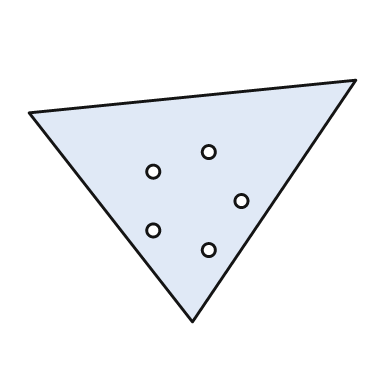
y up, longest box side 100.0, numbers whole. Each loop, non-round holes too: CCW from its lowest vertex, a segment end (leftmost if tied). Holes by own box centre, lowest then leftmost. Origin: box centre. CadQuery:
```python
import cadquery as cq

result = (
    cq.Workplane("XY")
    .moveTo(0.0, -37.0)
    .lineTo(50.0, 37.0)
    .lineTo(-50.0, 27.0)
    .close()
    .moveTo(5.0, -15.0)
    .circle(2.0)
    .moveTo(-12.0, -9.0)
    .circle(2.0)
    .moveTo(15.0, 0.0)
    .circle(2.0)
    .moveTo(-12.0, 9.0)
    .circle(2.0)
    .moveTo(5.0, 15.0)
    .circle(2.0)
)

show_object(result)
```